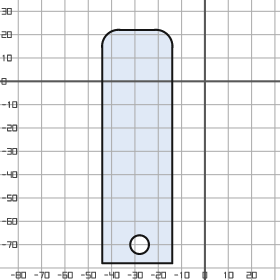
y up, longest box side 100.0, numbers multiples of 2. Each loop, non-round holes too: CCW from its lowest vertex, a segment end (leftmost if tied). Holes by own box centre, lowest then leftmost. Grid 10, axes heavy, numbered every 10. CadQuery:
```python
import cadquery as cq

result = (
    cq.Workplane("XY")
    .moveTo(-44.0, -78.0)
    .lineTo(-14.0, -78.0)
    .lineTo(-14.0, 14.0)
    .threePointArc((-16.0, 20.0), (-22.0, 22.0))
    .lineTo(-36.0, 22.0)
    .threePointArc((-42.0, 20.0), (-44.0, 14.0))
    .close()
    .moveTo(-28.0, -70.0)
    .circle(4.0)
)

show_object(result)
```